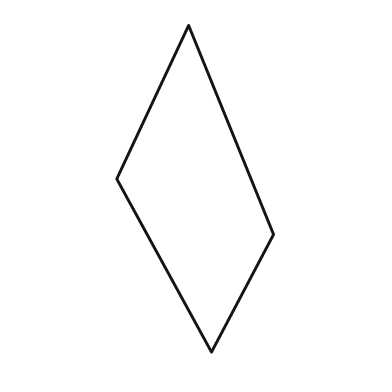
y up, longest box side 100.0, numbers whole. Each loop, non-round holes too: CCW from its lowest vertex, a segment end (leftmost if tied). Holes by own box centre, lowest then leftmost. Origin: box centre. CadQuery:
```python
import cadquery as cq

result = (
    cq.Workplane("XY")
    .moveTo(5.0, -50.0)
    .lineTo(24.0, -14.0)
    .lineTo(-2.0, 50.0)
    .lineTo(-24.0, 3.0)
    .close()
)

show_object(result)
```